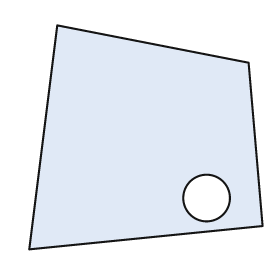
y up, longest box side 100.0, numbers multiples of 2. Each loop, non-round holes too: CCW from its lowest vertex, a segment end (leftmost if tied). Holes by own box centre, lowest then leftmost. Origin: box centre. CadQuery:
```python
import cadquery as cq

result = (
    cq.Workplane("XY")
    .moveTo(-50.0, -48.0)
    .lineTo(50.0, -38.0)
    .lineTo(44.0, 32.0)
    .lineTo(-38.0, 48.0)
    .close()
    .moveTo(26.0, -26.0)
    .circle(10.0)
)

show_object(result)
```